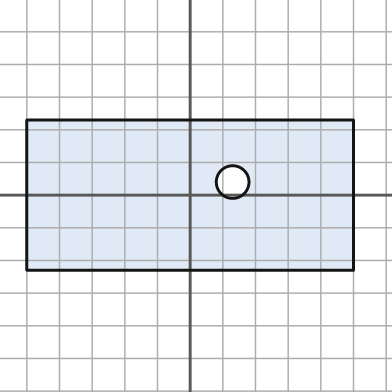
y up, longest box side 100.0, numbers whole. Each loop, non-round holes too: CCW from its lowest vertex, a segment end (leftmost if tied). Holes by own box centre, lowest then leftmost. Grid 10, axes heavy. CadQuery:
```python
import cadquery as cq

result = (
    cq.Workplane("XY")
    .moveTo(-50.0, -23.0)
    .lineTo(50.0, -23.0)
    .lineTo(50.0, 23.0)
    .lineTo(-50.0, 23.0)
    .close()
    .moveTo(13.0, 4.0)
    .circle(5.0)
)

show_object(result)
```